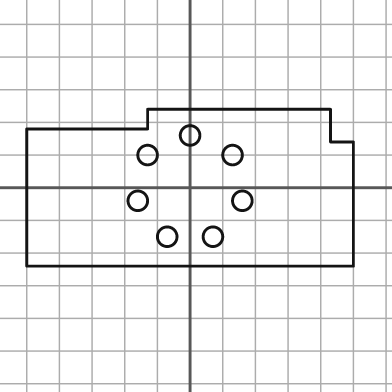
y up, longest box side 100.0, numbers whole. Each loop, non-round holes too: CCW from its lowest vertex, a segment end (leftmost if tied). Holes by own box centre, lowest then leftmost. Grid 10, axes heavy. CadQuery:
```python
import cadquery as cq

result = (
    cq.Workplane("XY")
    .moveTo(-50.0, -24.0)
    .lineTo(50.0, -24.0)
    .lineTo(50.0, 14.0)
    .lineTo(43.0, 14.0)
    .lineTo(43.0, 24.0)
    .lineTo(-13.0, 24.0)
    .lineTo(-13.0, 18.0)
    .lineTo(-50.0, 18.0)
    .close()
    .moveTo(-7.0, -15.0)
    .circle(3.0)
    .moveTo(7.0, -15.0)
    .circle(3.0)
    .moveTo(-16.0, -4.0)
    .circle(3.0)
    .moveTo(16.0, -4.0)
    .circle(3.0)
    .moveTo(-13.0, 10.0)
    .circle(3.0)
    .moveTo(13.0, 10.0)
    .circle(3.0)
    .moveTo(0.0, 16.0)
    .circle(3.0)
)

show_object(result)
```